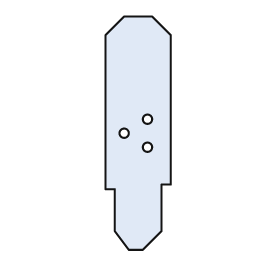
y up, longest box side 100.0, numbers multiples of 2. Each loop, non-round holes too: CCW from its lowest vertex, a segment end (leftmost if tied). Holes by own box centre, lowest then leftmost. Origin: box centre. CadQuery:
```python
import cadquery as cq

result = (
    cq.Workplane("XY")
    .moveTo(-4.0, -50.0)
    .lineTo(2.0, -50.0)
    .lineTo(10.0, -42.0)
    .lineTo(10.0, -22.0)
    .lineTo(14.0, -22.0)
    .lineTo(14.0, 42.0)
    .lineTo(6.0, 50.0)
    .lineTo(-6.0, 50.0)
    .lineTo(-14.0, 42.0)
    .lineTo(-14.0, -24.0)
    .lineTo(-10.0, -24.0)
    .lineTo(-10.0, -42.0)
    .close()
    .moveTo(4.0, -6.0)
    .circle(2.0)
    .moveTo(-6.0, 0.0)
    .circle(2.0)
    .moveTo(4.0, 6.0)
    .circle(2.0)
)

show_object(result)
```